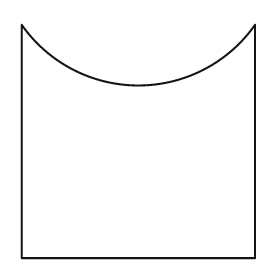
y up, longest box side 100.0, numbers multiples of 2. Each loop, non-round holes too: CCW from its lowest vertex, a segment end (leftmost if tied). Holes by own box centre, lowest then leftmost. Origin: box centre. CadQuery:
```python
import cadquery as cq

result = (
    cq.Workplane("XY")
    .moveTo(-50.0, -50.0)
    .lineTo(50.0, -50.0)
    .lineTo(50.0, 50.0)
    .threePointArc((0.0, 24.0), (-50.0, 50.0))
    .close()
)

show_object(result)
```